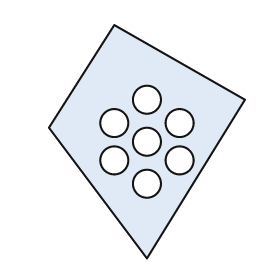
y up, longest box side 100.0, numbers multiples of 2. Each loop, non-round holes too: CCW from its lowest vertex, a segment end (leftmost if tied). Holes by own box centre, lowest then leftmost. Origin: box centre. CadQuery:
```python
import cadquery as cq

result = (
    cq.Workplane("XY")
    .moveTo(0.0, -50.0)
    .lineTo(42.0, 18.0)
    .lineTo(-14.0, 50.0)
    .lineTo(-42.0, 6.0)
    .close()
    .moveTo(0.0, -18.0)
    .circle(6.0)
    .moveTo(-14.0, -8.0)
    .circle(6.0)
    .moveTo(14.0, -8.0)
    .circle(6.0)
    .moveTo(0.0, 0.0)
    .circle(6.0)
    .moveTo(-14.0, 8.0)
    .circle(6.0)
    .moveTo(14.0, 8.0)
    .circle(6.0)
    .moveTo(0.0, 18.0)
    .circle(6.0)
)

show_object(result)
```